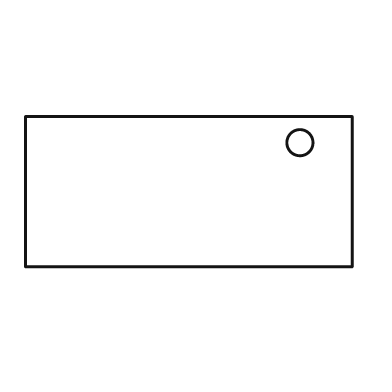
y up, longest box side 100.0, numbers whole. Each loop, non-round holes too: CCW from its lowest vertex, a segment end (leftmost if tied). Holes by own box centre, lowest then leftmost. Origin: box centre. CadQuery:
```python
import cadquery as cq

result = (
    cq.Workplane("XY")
    .moveTo(-50.0, -23.0)
    .lineTo(50.0, -23.0)
    .lineTo(50.0, 23.0)
    .lineTo(-50.0, 23.0)
    .close()
    .moveTo(34.0, 15.0)
    .circle(4.0)
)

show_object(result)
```